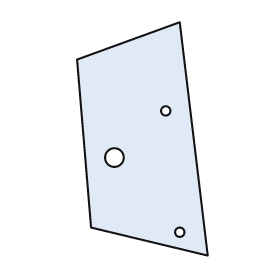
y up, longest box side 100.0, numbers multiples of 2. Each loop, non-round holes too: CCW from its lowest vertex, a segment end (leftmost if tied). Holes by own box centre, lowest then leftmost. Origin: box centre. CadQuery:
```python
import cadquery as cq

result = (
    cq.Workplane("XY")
    .moveTo(28.0, -50.0)
    .lineTo(16.0, 50.0)
    .lineTo(-28.0, 34.0)
    .lineTo(-22.0, -38.0)
    .close()
    .moveTo(16.0, -40.0)
    .circle(2.0)
    .moveTo(-12.0, -8.0)
    .circle(4.0)
    .moveTo(10.0, 12.0)
    .circle(2.0)
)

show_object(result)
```